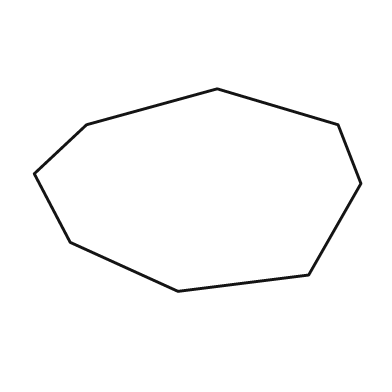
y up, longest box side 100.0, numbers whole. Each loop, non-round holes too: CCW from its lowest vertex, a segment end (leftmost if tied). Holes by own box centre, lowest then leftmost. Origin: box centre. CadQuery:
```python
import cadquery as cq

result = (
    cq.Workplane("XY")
    .moveTo(-6.0, -31.0)
    .lineTo(34.0, -26.0)
    .lineTo(50.0, 2.0)
    .lineTo(43.0, 20.0)
    .lineTo(6.0, 31.0)
    .lineTo(-34.0, 20.0)
    .lineTo(-50.0, 5.0)
    .lineTo(-39.0, -16.0)
    .close()
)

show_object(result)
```